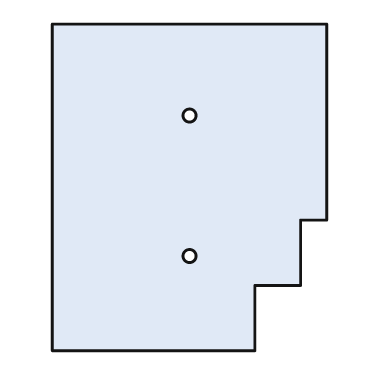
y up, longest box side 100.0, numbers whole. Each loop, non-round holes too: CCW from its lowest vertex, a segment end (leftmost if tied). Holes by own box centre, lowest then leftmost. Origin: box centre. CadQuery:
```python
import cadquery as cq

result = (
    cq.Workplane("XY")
    .moveTo(-42.0, -50.0)
    .lineTo(20.0, -50.0)
    .lineTo(20.0, -30.0)
    .lineTo(34.0, -30.0)
    .lineTo(34.0, -10.0)
    .lineTo(42.0, -10.0)
    .lineTo(42.0, 50.0)
    .lineTo(-42.0, 50.0)
    .close()
    .moveTo(0.0, -21.0)
    .circle(2.0)
    .moveTo(0.0, 22.0)
    .circle(2.0)
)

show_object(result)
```